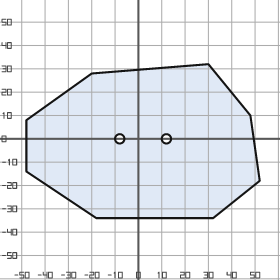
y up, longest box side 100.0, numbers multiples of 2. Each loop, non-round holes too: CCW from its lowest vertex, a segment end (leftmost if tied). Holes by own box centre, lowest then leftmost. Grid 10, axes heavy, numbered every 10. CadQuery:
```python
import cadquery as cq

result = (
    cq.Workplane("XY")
    .moveTo(-18.0, -34.0)
    .lineTo(32.0, -34.0)
    .lineTo(52.0, -18.0)
    .lineTo(48.0, 10.0)
    .lineTo(30.0, 32.0)
    .lineTo(-20.0, 28.0)
    .lineTo(-48.0, 8.0)
    .lineTo(-48.0, -14.0)
    .close()
    .moveTo(-8.0, 0.0)
    .circle(2.0)
    .moveTo(12.0, 0.0)
    .circle(2.0)
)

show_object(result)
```